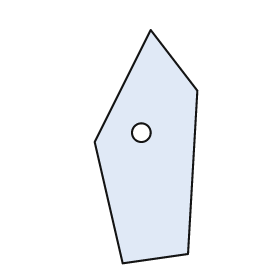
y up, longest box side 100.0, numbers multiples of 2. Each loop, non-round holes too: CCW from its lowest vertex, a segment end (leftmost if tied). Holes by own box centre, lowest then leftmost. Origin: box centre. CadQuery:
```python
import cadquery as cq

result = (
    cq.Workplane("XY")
    .moveTo(-10.0, -50.0)
    .lineTo(18.0, -46.0)
    .lineTo(22.0, 24.0)
    .lineTo(2.0, 50.0)
    .lineTo(-22.0, 2.0)
    .close()
    .moveTo(-2.0, 6.0)
    .circle(4.0)
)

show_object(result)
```